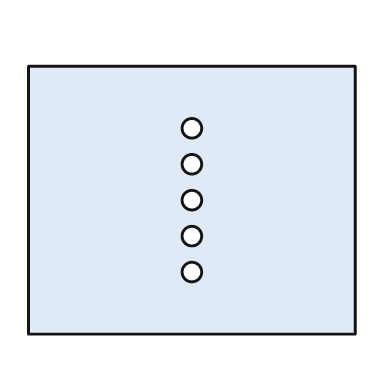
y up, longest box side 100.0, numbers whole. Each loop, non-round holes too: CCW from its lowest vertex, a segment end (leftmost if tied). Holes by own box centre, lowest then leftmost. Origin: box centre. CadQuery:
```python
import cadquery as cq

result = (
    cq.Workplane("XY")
    .moveTo(-50.0, -41.0)
    .lineTo(50.0, -41.0)
    .lineTo(50.0, 41.0)
    .lineTo(-50.0, 41.0)
    .close()
    .moveTo(0.0, -22.0)
    .circle(3.0)
    .moveTo(0.0, -11.0)
    .circle(3.0)
    .moveTo(0.0, 0.0)
    .circle(3.0)
    .moveTo(0.0, 11.0)
    .circle(3.0)
    .moveTo(0.0, 22.0)
    .circle(3.0)
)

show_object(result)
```